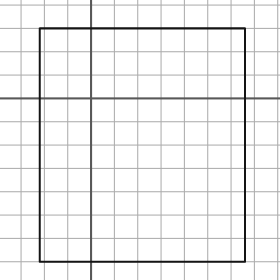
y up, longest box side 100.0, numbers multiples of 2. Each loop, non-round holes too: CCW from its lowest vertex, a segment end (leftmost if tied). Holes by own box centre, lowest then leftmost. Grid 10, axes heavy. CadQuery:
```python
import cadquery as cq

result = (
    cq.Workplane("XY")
    .moveTo(-22.0, -70.0)
    .lineTo(66.0, -70.0)
    .lineTo(66.0, 30.0)
    .lineTo(-22.0, 30.0)
    .close()
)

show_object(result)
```